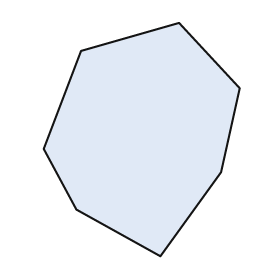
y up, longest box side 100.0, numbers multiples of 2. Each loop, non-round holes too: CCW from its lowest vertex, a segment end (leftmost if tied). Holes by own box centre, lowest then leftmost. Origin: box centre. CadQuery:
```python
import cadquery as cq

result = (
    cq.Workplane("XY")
    .moveTo(8.0, -50.0)
    .lineTo(34.0, -14.0)
    .lineTo(42.0, 22.0)
    .lineTo(16.0, 50.0)
    .lineTo(-26.0, 38.0)
    .lineTo(-42.0, -4.0)
    .lineTo(-28.0, -30.0)
    .close()
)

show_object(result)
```